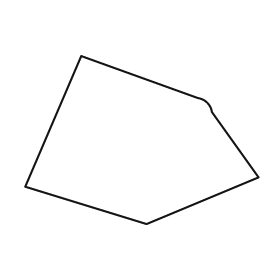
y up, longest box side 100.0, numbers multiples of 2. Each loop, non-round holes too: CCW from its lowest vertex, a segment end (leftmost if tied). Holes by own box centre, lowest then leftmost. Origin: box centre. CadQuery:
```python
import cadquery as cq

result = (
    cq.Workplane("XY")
    .moveTo(2.0, -36.0)
    .lineTo(50.0, -16.0)
    .lineTo(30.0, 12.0)
    .threePointArc((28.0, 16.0), (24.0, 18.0))
    .lineTo(-26.0, 36.0)
    .lineTo(-50.0, -20.0)
    .close()
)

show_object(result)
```